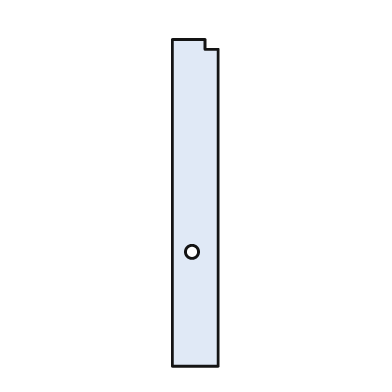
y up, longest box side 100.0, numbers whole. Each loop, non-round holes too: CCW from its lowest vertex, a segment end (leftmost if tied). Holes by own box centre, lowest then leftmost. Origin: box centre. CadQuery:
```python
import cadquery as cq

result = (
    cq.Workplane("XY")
    .moveTo(-7.0, -50.0)
    .lineTo(7.0, -50.0)
    .lineTo(7.0, 47.0)
    .lineTo(3.0, 47.0)
    .lineTo(3.0, 50.0)
    .lineTo(-7.0, 50.0)
    .close()
    .moveTo(-1.0, -15.0)
    .circle(2.0)
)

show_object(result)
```